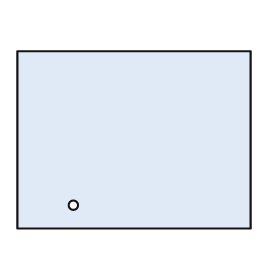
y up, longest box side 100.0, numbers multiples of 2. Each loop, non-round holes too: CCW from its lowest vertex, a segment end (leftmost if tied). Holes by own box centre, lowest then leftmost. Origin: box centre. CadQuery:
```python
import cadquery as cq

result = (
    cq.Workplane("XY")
    .moveTo(-50.0, -38.0)
    .lineTo(50.0, -38.0)
    .lineTo(50.0, 38.0)
    .lineTo(-50.0, 38.0)
    .close()
    .moveTo(-26.0, -28.0)
    .circle(2.0)
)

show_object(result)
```